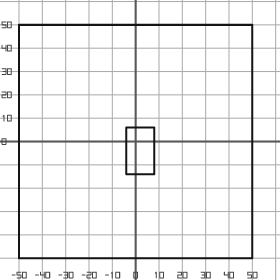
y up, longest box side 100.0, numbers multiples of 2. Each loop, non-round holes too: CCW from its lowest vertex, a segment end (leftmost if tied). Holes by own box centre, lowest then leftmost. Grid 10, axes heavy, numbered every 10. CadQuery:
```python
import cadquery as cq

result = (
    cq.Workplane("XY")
    .moveTo(-50.0, -50.0)
    .lineTo(50.0, -50.0)
    .lineTo(50.0, 50.0)
    .lineTo(-50.0, 50.0)
    .close()
    .moveTo(-4.0, -14.0)
    .lineTo(8.0, -14.0)
    .lineTo(8.0, 6.0)
    .lineTo(-4.0, 6.0)
    .close()
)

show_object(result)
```